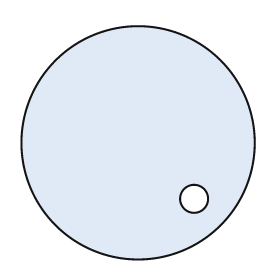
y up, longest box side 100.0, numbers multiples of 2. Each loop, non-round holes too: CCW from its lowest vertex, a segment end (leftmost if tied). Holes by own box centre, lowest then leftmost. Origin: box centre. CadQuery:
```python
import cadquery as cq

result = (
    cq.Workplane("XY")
    .moveTo(0.0, 0.0)
    .circle(50.0)
    .moveTo(24.0, -24.0)
    .circle(6.0)
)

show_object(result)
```